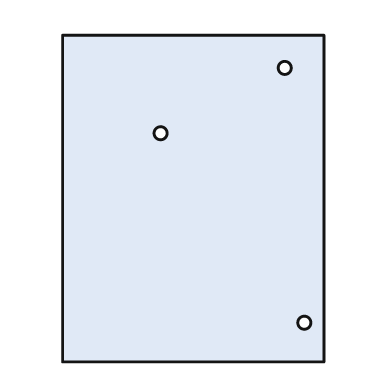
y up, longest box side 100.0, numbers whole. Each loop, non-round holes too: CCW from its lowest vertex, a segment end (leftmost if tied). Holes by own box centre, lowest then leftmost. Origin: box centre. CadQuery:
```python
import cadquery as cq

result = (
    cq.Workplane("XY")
    .moveTo(-40.0, -50.0)
    .lineTo(40.0, -50.0)
    .lineTo(40.0, 50.0)
    .lineTo(-40.0, 50.0)
    .close()
    .moveTo(34.0, -38.0)
    .circle(2.0)
    .moveTo(-10.0, 20.0)
    .circle(2.0)
    .moveTo(28.0, 40.0)
    .circle(2.0)
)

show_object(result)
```